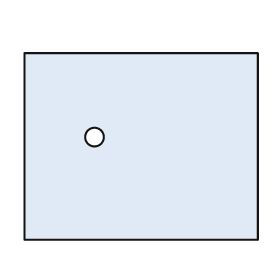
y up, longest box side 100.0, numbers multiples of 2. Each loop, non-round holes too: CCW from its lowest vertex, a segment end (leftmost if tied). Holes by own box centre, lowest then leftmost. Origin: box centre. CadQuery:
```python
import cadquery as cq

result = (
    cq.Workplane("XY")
    .moveTo(-50.0, -40.0)
    .lineTo(50.0, -40.0)
    .lineTo(50.0, 40.0)
    .lineTo(-50.0, 40.0)
    .close()
    .moveTo(-20.0, 4.0)
    .circle(4.0)
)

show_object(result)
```